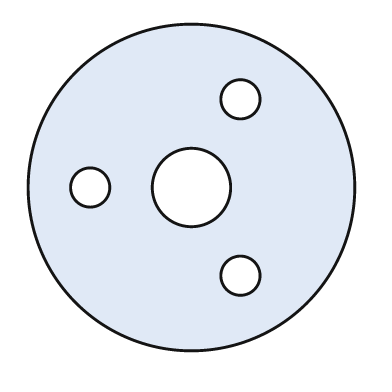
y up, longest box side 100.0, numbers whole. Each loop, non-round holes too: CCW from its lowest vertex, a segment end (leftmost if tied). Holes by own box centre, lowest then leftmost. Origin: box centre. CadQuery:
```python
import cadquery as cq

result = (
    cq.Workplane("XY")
    .moveTo(0.0, 0.0)
    .circle(50.0)
    .moveTo(15.0, -27.0)
    .circle(6.0)
    .moveTo(-31.0, 0.0)
    .circle(6.0)
    .moveTo(0.0, 0.0)
    .circle(12.0)
    .moveTo(15.0, 27.0)
    .circle(6.0)
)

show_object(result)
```